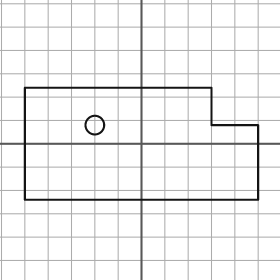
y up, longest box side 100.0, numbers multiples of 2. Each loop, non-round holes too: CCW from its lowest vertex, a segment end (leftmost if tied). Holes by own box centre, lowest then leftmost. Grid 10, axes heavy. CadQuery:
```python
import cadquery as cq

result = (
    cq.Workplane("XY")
    .moveTo(-50.0, -24.0)
    .lineTo(50.0, -24.0)
    .lineTo(50.0, 8.0)
    .lineTo(30.0, 8.0)
    .lineTo(30.0, 24.0)
    .lineTo(-50.0, 24.0)
    .close()
    .moveTo(-20.0, 8.0)
    .circle(4.0)
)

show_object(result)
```